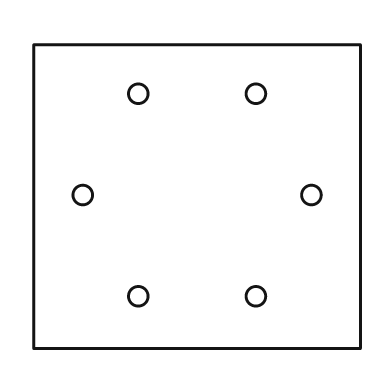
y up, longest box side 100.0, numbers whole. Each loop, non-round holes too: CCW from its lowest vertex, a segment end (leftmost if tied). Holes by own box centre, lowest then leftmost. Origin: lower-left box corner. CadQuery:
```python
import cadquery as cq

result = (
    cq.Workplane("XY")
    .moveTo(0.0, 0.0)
    .lineTo(100.0, 0.0)
    .lineTo(100.0, 93.0)
    .lineTo(0.0, 93.0)
    .close()
    .moveTo(32.0, 16.0)
    .circle(3.0)
    .moveTo(68.0, 16.0)
    .circle(3.0)
    .moveTo(15.0, 47.0)
    .circle(3.0)
    .moveTo(85.0, 47.0)
    .circle(3.0)
    .moveTo(32.0, 78.0)
    .circle(3.0)
    .moveTo(68.0, 78.0)
    .circle(3.0)
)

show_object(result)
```